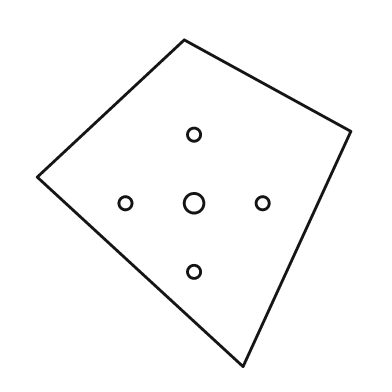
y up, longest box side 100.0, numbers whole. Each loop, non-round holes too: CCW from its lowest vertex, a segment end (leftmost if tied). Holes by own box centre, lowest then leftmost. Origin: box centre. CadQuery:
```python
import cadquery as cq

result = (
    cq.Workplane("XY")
    .moveTo(15.0, -50.0)
    .lineTo(48.0, 22.0)
    .lineTo(-3.0, 50.0)
    .lineTo(-48.0, 8.0)
    .close()
    .moveTo(0.0, -21.0)
    .circle(2.0)
    .moveTo(-21.0, 0.0)
    .circle(2.0)
    .moveTo(0.0, 0.0)
    .circle(3.0)
    .moveTo(21.0, 0.0)
    .circle(2.0)
    .moveTo(0.0, 21.0)
    .circle(2.0)
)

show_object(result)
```